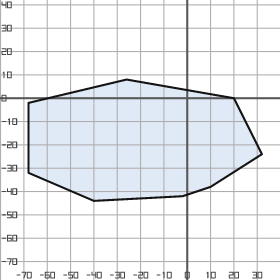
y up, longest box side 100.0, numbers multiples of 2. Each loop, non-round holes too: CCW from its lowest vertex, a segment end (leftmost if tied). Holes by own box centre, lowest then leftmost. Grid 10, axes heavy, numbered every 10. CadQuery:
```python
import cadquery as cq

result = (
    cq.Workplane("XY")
    .moveTo(-40.0, -44.0)
    .lineTo(-2.0, -42.0)
    .lineTo(10.0, -38.0)
    .lineTo(32.0, -24.0)
    .lineTo(20.0, 0.0)
    .lineTo(-26.0, 8.0)
    .lineTo(-68.0, -2.0)
    .lineTo(-68.0, -32.0)
    .close()
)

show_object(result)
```